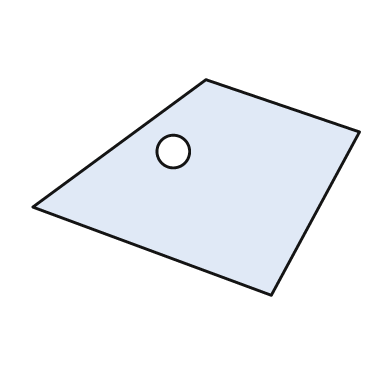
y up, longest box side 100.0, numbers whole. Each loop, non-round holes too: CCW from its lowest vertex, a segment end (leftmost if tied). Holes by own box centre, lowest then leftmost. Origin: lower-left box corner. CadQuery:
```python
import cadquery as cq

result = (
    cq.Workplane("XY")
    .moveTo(73.0, 0.0)
    .lineTo(100.0, 50.0)
    .lineTo(53.0, 66.0)
    .lineTo(0.0, 27.0)
    .close()
    .moveTo(43.0, 44.0)
    .circle(5.0)
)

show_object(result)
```